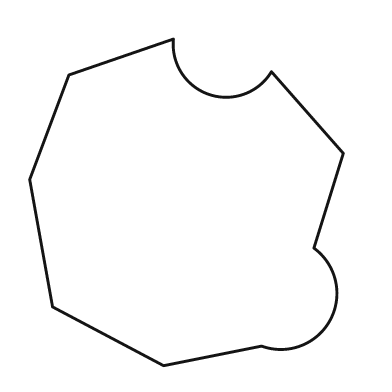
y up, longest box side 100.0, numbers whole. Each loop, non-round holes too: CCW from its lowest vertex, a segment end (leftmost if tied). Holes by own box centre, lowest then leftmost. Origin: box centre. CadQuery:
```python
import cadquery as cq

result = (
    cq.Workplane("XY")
    .moveTo(-7.0, -50.0)
    .lineTo(23.0, -44.0)
    .threePointArc((44.0, -36.0), (39.0, -14.0))
    .lineTo(48.0, 15.0)
    .lineTo(26.0, 40.0)
    .threePointArc((7.0, 33.0), (-4.0, 50.0))
    .lineTo(-36.0, 39.0)
    .lineTo(-48.0, 7.0)
    .lineTo(-41.0, -32.0)
    .close()
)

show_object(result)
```